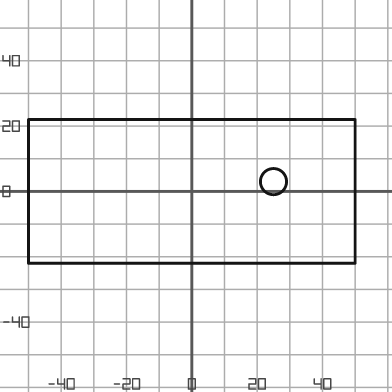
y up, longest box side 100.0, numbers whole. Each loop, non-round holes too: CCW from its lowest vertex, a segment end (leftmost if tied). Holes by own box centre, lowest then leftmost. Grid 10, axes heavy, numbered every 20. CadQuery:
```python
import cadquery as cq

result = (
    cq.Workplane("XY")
    .moveTo(-50.0, -22.0)
    .lineTo(50.0, -22.0)
    .lineTo(50.0, 22.0)
    .lineTo(-50.0, 22.0)
    .close()
    .moveTo(25.0, 3.0)
    .circle(4.0)
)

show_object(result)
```